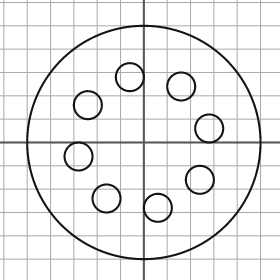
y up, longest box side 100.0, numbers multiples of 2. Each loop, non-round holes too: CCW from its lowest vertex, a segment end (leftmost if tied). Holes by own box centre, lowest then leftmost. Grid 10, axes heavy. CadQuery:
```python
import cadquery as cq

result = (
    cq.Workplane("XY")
    .moveTo(0.0, 0.0)
    .circle(50.0)
    .moveTo(6.0, -28.0)
    .circle(6.0)
    .moveTo(-16.0, -24.0)
    .circle(6.0)
    .moveTo(24.0, -16.0)
    .circle(6.0)
    .moveTo(-28.0, -6.0)
    .circle(6.0)
    .moveTo(28.0, 6.0)
    .circle(6.0)
    .moveTo(-24.0, 16.0)
    .circle(6.0)
    .moveTo(16.0, 24.0)
    .circle(6.0)
    .moveTo(-6.0, 28.0)
    .circle(6.0)
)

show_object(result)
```